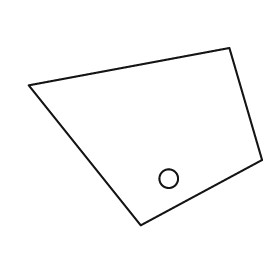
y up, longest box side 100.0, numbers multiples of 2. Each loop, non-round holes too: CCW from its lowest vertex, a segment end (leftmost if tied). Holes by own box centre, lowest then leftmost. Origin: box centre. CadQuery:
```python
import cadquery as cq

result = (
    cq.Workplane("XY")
    .moveTo(-2.0, -38.0)
    .lineTo(50.0, -10.0)
    .lineTo(36.0, 38.0)
    .lineTo(-50.0, 22.0)
    .close()
    .moveTo(10.0, -18.0)
    .circle(4.0)
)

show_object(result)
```